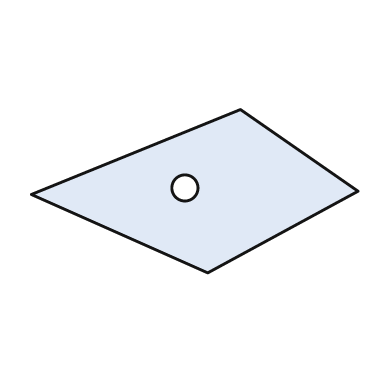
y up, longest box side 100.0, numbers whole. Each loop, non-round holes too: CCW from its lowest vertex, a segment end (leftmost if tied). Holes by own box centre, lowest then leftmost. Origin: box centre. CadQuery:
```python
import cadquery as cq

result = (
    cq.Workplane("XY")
    .moveTo(4.0, -25.0)
    .lineTo(50.0, 0.0)
    .lineTo(14.0, 25.0)
    .lineTo(-50.0, -1.0)
    .close()
    .moveTo(-3.0, 1.0)
    .circle(4.0)
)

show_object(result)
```